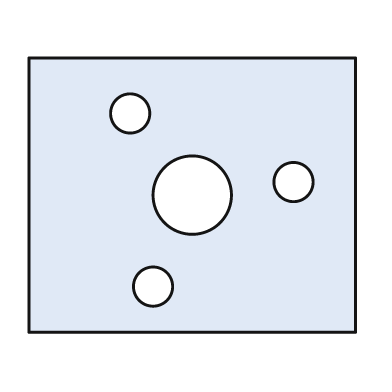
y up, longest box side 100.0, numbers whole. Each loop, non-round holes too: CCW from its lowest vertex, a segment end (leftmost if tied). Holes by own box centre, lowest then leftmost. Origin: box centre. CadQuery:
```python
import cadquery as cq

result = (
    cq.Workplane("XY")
    .moveTo(-50.0, -42.0)
    .lineTo(50.0, -42.0)
    .lineTo(50.0, 42.0)
    .lineTo(-50.0, 42.0)
    .close()
    .moveTo(-12.0, -28.0)
    .circle(6.0)
    .moveTo(0.0, 0.0)
    .circle(12.0)
    .moveTo(31.0, 4.0)
    .circle(6.0)
    .moveTo(-19.0, 25.0)
    .circle(6.0)
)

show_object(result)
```